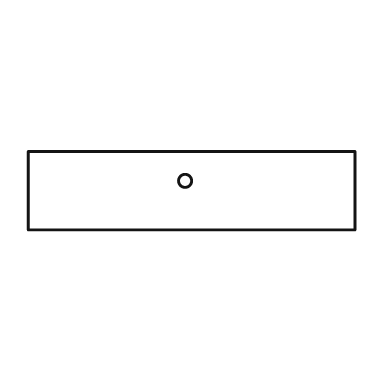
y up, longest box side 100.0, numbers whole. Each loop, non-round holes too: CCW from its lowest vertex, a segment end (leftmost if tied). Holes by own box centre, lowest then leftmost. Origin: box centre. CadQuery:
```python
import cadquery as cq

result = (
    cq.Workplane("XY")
    .moveTo(-50.0, -12.0)
    .lineTo(50.0, -12.0)
    .lineTo(50.0, 12.0)
    .lineTo(-50.0, 12.0)
    .close()
    .moveTo(-2.0, 3.0)
    .circle(2.0)
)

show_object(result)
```